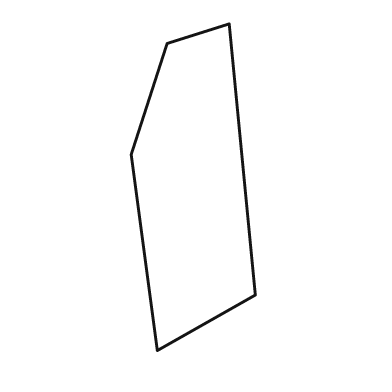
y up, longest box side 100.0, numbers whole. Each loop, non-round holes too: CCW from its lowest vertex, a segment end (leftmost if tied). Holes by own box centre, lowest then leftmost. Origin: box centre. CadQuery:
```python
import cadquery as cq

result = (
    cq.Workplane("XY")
    .moveTo(-11.0, -50.0)
    .lineTo(19.0, -33.0)
    .lineTo(11.0, 50.0)
    .lineTo(-8.0, 44.0)
    .lineTo(-19.0, 10.0)
    .close()
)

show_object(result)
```